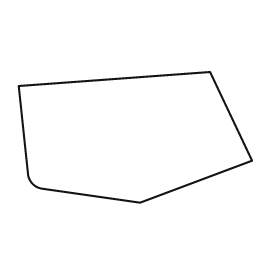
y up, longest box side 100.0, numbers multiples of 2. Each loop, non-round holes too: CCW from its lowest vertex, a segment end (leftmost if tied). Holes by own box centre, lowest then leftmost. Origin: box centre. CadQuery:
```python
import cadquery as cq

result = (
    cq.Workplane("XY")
    .moveTo(2.0, -28.0)
    .lineTo(50.0, -10.0)
    .lineTo(32.0, 28.0)
    .lineTo(-50.0, 22.0)
    .lineTo(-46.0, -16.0)
    .threePointArc((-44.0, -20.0), (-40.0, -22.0))
    .close()
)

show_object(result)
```